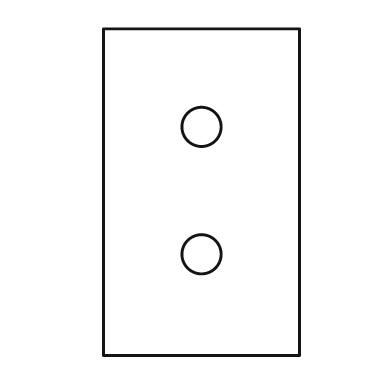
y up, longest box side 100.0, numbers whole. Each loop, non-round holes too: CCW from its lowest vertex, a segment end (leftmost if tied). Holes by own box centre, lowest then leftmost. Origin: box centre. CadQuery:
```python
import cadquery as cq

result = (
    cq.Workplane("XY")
    .moveTo(-30.0, -50.0)
    .lineTo(30.0, -50.0)
    .lineTo(30.0, 50.0)
    .lineTo(-30.0, 50.0)
    .close()
    .moveTo(0.0, -19.0)
    .circle(6.0)
    .moveTo(0.0, 20.0)
    .circle(6.0)
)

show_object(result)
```